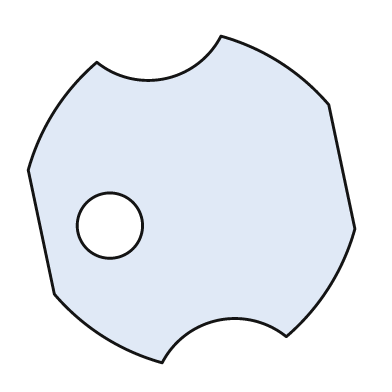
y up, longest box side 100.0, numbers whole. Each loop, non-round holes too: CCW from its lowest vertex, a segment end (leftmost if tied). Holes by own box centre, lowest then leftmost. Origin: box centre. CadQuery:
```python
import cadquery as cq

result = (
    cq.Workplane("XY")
    .moveTo(-9.0, -50.0)
    .threePointArc((8.0, -37.0), (29.0, -42.0))
    .threePointArc((42.0, -27.0), (50.0, -9.0))
    .lineTo(42.0, 29.0)
    .threePointArc((27.0, 42.0), (9.0, 50.0))
    .threePointArc((-8.0, 37.0), (-29.0, 42.0))
    .threePointArc((-42.0, 27.0), (-50.0, 9.0))
    .lineTo(-42.0, -29.0)
    .threePointArc((-27.0, -42.0), (-9.0, -50.0))
    .close()
    .moveTo(-25.0, -8.0)
    .circle(10.0)
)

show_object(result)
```